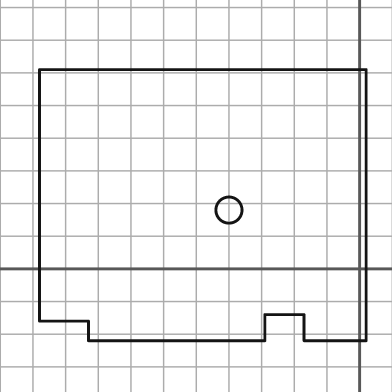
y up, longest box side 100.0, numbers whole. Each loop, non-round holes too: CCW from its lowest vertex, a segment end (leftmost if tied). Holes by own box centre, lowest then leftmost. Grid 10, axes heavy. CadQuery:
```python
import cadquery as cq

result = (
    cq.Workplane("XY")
    .moveTo(-83.0, -22.0)
    .lineTo(-29.0, -22.0)
    .lineTo(-29.0, -14.0)
    .lineTo(-17.0, -14.0)
    .lineTo(-17.0, -22.0)
    .lineTo(2.0, -22.0)
    .lineTo(2.0, 61.0)
    .lineTo(-98.0, 61.0)
    .lineTo(-98.0, -16.0)
    .lineTo(-83.0, -16.0)
    .close()
    .moveTo(-40.0, 18.0)
    .circle(4.0)
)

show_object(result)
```